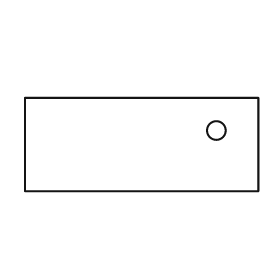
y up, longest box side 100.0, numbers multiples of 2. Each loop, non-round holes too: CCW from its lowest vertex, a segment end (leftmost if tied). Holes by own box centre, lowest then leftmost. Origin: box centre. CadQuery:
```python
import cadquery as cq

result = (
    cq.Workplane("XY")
    .moveTo(-50.0, -20.0)
    .lineTo(50.0, -20.0)
    .lineTo(50.0, 20.0)
    .lineTo(-50.0, 20.0)
    .close()
    .moveTo(32.0, 6.0)
    .circle(4.0)
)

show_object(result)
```